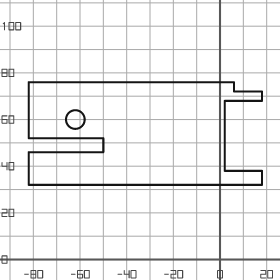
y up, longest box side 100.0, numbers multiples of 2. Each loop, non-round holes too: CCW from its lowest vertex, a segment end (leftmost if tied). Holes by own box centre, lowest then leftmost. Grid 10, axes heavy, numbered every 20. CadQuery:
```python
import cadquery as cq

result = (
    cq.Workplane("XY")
    .moveTo(-82.0, 32.0)
    .lineTo(18.0, 32.0)
    .lineTo(18.0, 38.0)
    .lineTo(2.0, 38.0)
    .lineTo(2.0, 68.0)
    .lineTo(18.0, 68.0)
    .lineTo(18.0, 72.0)
    .lineTo(6.0, 72.0)
    .lineTo(6.0, 76.0)
    .lineTo(-82.0, 76.0)
    .lineTo(-82.0, 52.0)
    .lineTo(-50.0, 52.0)
    .lineTo(-50.0, 46.0)
    .lineTo(-82.0, 46.0)
    .close()
    .moveTo(-62.0, 60.0)
    .circle(4.0)
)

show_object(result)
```